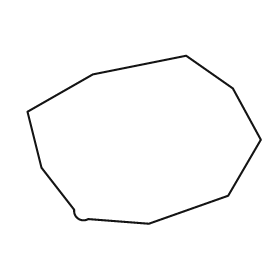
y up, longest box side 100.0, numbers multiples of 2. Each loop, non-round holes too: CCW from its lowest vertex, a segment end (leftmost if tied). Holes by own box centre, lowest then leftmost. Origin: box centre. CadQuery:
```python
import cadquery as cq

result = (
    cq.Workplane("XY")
    .moveTo(2.0, -36.0)
    .lineTo(36.0, -24.0)
    .lineTo(50.0, 0.0)
    .lineTo(38.0, 22.0)
    .lineTo(18.0, 36.0)
    .lineTo(-22.0, 28.0)
    .lineTo(-50.0, 12.0)
    .lineTo(-44.0, -12.0)
    .lineTo(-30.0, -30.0)
    .threePointArc((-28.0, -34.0), (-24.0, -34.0))
    .close()
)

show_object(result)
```